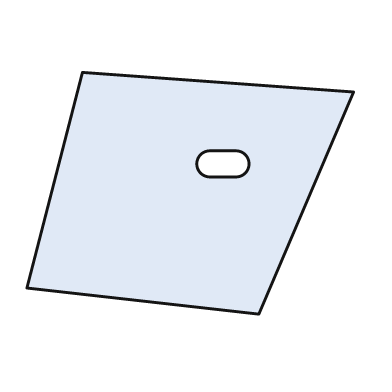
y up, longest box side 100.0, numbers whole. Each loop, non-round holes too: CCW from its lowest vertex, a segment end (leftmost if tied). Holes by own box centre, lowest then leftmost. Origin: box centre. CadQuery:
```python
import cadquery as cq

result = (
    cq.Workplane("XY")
    .moveTo(21.0, -37.0)
    .lineTo(50.0, 31.0)
    .lineTo(-33.0, 37.0)
    .lineTo(-50.0, -29.0)
    .close()
    .moveTo(6.0, 5.0)
    .lineTo(14.0, 5.0)
    .threePointArc((18.0, 9.0), (14.0, 13.0))
    .lineTo(6.0, 13.0)
    .threePointArc((2.0, 9.0), (6.0, 5.0))
    .close()
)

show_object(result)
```